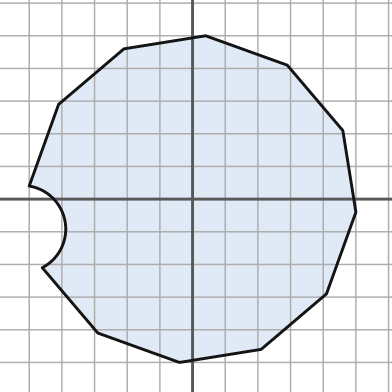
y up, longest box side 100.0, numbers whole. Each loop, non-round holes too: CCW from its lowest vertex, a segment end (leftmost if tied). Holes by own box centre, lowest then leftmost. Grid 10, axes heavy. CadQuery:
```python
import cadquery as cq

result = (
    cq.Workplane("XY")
    .moveTo(-4.0, -50.0)
    .lineTo(21.0, -46.0)
    .lineTo(41.0, -29.0)
    .lineTo(50.0, -4.0)
    .lineTo(46.0, 21.0)
    .lineTo(29.0, 41.0)
    .lineTo(4.0, 50.0)
    .lineTo(-21.0, 46.0)
    .lineTo(-41.0, 29.0)
    .lineTo(-50.0, 4.0)
    .threePointArc((-39.0, -7.0), (-46.0, -21.0))
    .lineTo(-29.0, -41.0)
    .close()
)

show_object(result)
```